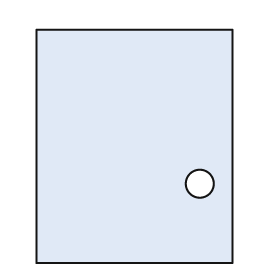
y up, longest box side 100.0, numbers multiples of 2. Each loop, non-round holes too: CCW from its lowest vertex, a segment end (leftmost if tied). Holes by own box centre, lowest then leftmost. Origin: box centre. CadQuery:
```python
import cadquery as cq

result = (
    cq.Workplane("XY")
    .moveTo(-42.0, -50.0)
    .lineTo(42.0, -50.0)
    .lineTo(42.0, 50.0)
    .lineTo(-42.0, 50.0)
    .close()
    .moveTo(28.0, -16.0)
    .circle(6.0)
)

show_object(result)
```